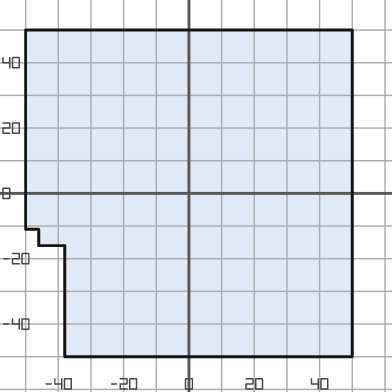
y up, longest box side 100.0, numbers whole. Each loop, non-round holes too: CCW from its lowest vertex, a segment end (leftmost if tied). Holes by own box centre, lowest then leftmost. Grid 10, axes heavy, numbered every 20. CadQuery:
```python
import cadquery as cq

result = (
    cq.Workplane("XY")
    .moveTo(-38.0, -50.0)
    .lineTo(50.0, -50.0)
    .lineTo(50.0, 50.0)
    .lineTo(-50.0, 50.0)
    .lineTo(-50.0, -11.0)
    .lineTo(-46.0, -11.0)
    .lineTo(-46.0, -16.0)
    .lineTo(-38.0, -16.0)
    .close()
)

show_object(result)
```